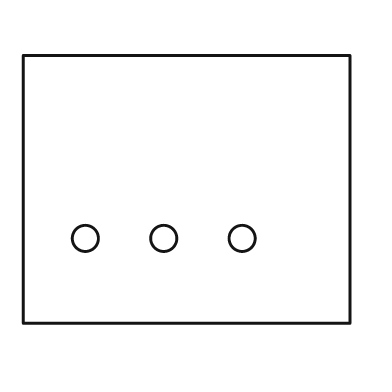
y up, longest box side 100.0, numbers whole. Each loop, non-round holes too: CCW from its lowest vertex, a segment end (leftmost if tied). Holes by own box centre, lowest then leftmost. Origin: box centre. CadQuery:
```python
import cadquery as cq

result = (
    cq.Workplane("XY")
    .moveTo(-50.0, -41.0)
    .lineTo(50.0, -41.0)
    .lineTo(50.0, 41.0)
    .lineTo(-50.0, 41.0)
    .close()
    .moveTo(-31.0, -15.0)
    .circle(4.0)
    .moveTo(-7.0, -15.0)
    .circle(4.0)
    .moveTo(17.0, -15.0)
    .circle(4.0)
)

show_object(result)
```